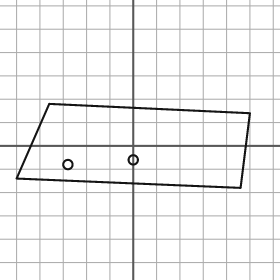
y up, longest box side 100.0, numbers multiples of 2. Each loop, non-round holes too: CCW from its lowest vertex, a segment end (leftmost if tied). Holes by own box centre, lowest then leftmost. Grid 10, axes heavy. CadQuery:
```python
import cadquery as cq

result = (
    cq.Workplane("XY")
    .moveTo(46.0, -18.0)
    .lineTo(50.0, 14.0)
    .lineTo(-36.0, 18.0)
    .lineTo(-50.0, -14.0)
    .close()
    .moveTo(-28.0, -8.0)
    .circle(2.0)
    .moveTo(0.0, -6.0)
    .circle(2.0)
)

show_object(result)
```